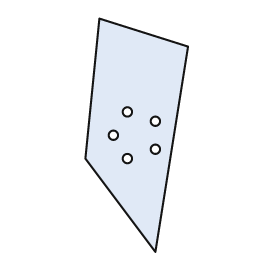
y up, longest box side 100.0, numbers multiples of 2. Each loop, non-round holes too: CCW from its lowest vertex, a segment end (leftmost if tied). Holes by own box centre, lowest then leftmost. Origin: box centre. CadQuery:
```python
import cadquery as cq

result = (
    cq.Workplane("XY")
    .moveTo(8.0, -50.0)
    .lineTo(22.0, 38.0)
    .lineTo(-16.0, 50.0)
    .lineTo(-22.0, -10.0)
    .close()
    .moveTo(-4.0, -10.0)
    .circle(2.0)
    .moveTo(8.0, -6.0)
    .circle(2.0)
    .moveTo(-10.0, 0.0)
    .circle(2.0)
    .moveTo(8.0, 6.0)
    .circle(2.0)
    .moveTo(-4.0, 10.0)
    .circle(2.0)
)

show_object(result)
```